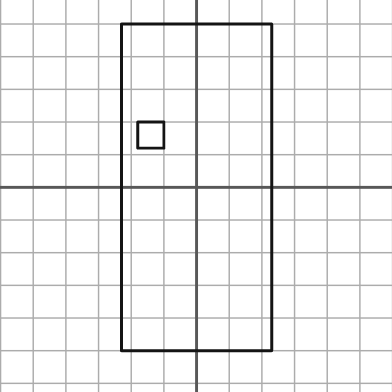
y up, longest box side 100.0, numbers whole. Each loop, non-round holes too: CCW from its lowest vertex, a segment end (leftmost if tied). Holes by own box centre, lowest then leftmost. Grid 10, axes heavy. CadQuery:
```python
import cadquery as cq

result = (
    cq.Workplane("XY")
    .moveTo(-23.0, -50.0)
    .lineTo(23.0, -50.0)
    .lineTo(23.0, 50.0)
    .lineTo(-23.0, 50.0)
    .close()
    .moveTo(-18.0, 12.0)
    .lineTo(-10.0, 12.0)
    .lineTo(-10.0, 20.0)
    .lineTo(-18.0, 20.0)
    .close()
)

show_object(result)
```